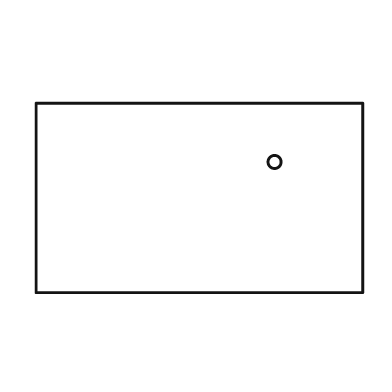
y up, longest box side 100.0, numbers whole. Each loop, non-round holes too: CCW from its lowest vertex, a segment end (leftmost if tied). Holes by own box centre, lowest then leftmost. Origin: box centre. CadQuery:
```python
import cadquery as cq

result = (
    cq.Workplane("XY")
    .moveTo(-50.0, -29.0)
    .lineTo(50.0, -29.0)
    .lineTo(50.0, 29.0)
    .lineTo(-50.0, 29.0)
    .close()
    .moveTo(23.0, 11.0)
    .circle(2.0)
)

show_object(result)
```